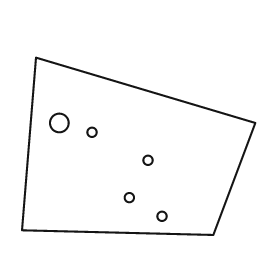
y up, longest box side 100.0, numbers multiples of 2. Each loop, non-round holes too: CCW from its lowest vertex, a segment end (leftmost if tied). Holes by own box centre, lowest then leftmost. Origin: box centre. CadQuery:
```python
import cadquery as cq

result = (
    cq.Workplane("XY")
    .moveTo(32.0, -38.0)
    .lineTo(50.0, 10.0)
    .lineTo(-44.0, 38.0)
    .lineTo(-50.0, -36.0)
    .close()
    .moveTo(10.0, -30.0)
    .circle(2.0)
    .moveTo(-4.0, -22.0)
    .circle(2.0)
    .moveTo(4.0, -6.0)
    .circle(2.0)
    .moveTo(-20.0, 6.0)
    .circle(2.0)
    .moveTo(-34.0, 10.0)
    .circle(4.0)
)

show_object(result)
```